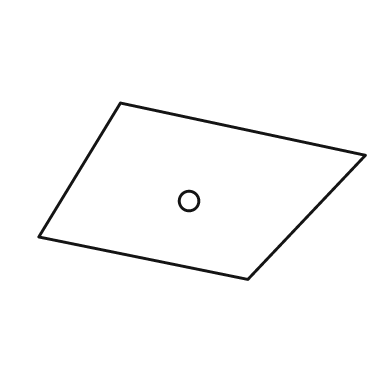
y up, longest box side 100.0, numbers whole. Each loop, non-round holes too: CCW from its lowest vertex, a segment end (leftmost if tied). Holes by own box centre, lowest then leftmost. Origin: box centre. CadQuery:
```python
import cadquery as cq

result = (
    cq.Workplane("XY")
    .moveTo(14.0, -27.0)
    .lineTo(50.0, 11.0)
    .lineTo(-25.0, 27.0)
    .lineTo(-50.0, -14.0)
    .close()
    .moveTo(-4.0, -3.0)
    .circle(3.0)
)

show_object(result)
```